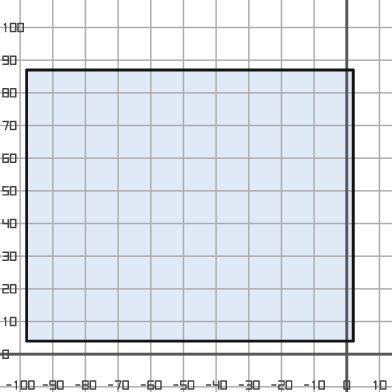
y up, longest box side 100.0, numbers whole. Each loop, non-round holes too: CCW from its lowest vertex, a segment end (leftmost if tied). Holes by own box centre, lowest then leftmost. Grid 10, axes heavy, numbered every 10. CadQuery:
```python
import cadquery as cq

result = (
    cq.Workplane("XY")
    .moveTo(-98.0, 4.0)
    .lineTo(2.0, 4.0)
    .lineTo(2.0, 87.0)
    .lineTo(-98.0, 87.0)
    .close()
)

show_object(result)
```